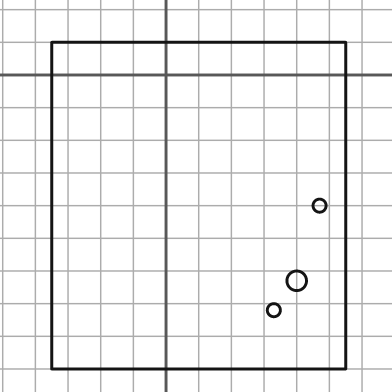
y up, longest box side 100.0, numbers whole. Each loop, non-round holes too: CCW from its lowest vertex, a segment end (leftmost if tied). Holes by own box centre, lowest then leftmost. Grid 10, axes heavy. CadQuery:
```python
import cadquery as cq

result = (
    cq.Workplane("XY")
    .moveTo(-35.0, -90.0)
    .lineTo(55.0, -90.0)
    .lineTo(55.0, 10.0)
    .lineTo(-35.0, 10.0)
    .close()
    .moveTo(33.0, -72.0)
    .circle(2.0)
    .moveTo(40.0, -63.0)
    .circle(3.0)
    .moveTo(47.0, -40.0)
    .circle(2.0)
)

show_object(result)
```